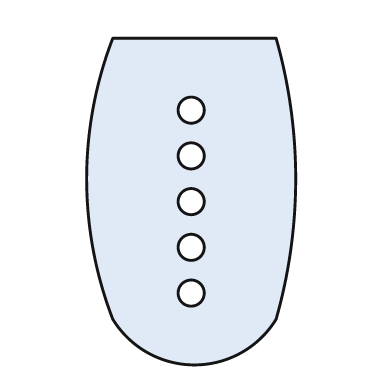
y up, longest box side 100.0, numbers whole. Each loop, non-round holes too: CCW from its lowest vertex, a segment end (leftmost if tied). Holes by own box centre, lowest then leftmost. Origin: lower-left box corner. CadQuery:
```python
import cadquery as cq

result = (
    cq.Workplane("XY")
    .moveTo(8.0, 14.0)
    .threePointArc((33.0, 0.0), (58.0, 14.0))
    .threePointArc((64.0, 57.0), (58.0, 100.0))
    .lineTo(8.0, 100.0)
    .threePointArc((0.0, 57.0), (8.0, 14.0))
    .close()
    .moveTo(32.0, 22.0)
    .circle(4.0)
    .moveTo(32.0, 36.0)
    .circle(4.0)
    .moveTo(32.0, 50.0)
    .circle(4.0)
    .moveTo(32.0, 64.0)
    .circle(4.0)
    .moveTo(32.0, 78.0)
    .circle(4.0)
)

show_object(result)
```